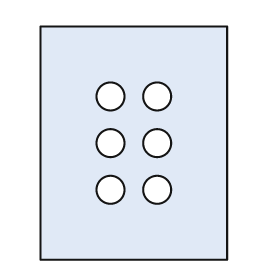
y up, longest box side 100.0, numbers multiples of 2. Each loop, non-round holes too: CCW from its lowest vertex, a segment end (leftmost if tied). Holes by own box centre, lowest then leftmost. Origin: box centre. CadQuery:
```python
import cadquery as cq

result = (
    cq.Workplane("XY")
    .moveTo(-40.0, -50.0)
    .lineTo(40.0, -50.0)
    .lineTo(40.0, 50.0)
    .lineTo(-40.0, 50.0)
    .close()
    .moveTo(-10.0, -20.0)
    .circle(6.0)
    .moveTo(10.0, -20.0)
    .circle(6.0)
    .moveTo(-10.0, 0.0)
    .circle(6.0)
    .moveTo(10.0, 0.0)
    .circle(6.0)
    .moveTo(-10.0, 20.0)
    .circle(6.0)
    .moveTo(10.0, 20.0)
    .circle(6.0)
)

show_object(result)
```